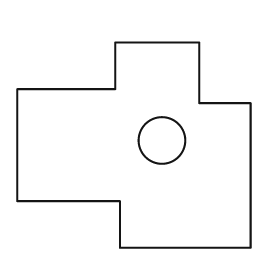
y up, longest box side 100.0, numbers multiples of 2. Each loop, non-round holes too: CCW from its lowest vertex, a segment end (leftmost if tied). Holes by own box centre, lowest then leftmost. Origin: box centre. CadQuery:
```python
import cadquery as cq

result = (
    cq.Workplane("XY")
    .moveTo(-6.0, -44.0)
    .lineTo(50.0, -44.0)
    .lineTo(50.0, 18.0)
    .lineTo(28.0, 18.0)
    .lineTo(28.0, 44.0)
    .lineTo(-8.0, 44.0)
    .lineTo(-8.0, 24.0)
    .lineTo(-50.0, 24.0)
    .lineTo(-50.0, -24.0)
    .lineTo(-6.0, -24.0)
    .close()
    .moveTo(12.0, 2.0)
    .circle(10.0)
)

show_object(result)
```